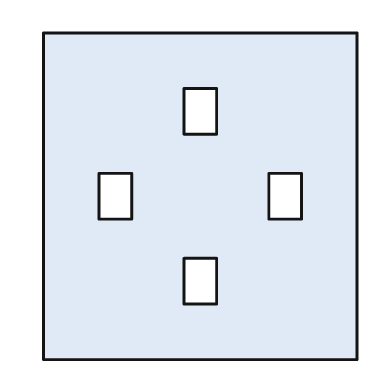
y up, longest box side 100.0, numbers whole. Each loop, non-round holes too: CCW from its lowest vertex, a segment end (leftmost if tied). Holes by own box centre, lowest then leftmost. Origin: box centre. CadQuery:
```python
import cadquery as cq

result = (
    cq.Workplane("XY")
    .moveTo(-48.0, -50.0)
    .lineTo(48.0, -50.0)
    .lineTo(48.0, 50.0)
    .lineTo(-48.0, 50.0)
    .close()
    .moveTo(-5.0, -33.0)
    .lineTo(5.0, -33.0)
    .lineTo(5.0, -19.0)
    .lineTo(-5.0, -19.0)
    .close()
    .moveTo(-31.0, -7.0)
    .lineTo(-21.0, -7.0)
    .lineTo(-21.0, 7.0)
    .lineTo(-31.0, 7.0)
    .close()
    .moveTo(21.0, -7.0)
    .lineTo(31.0, -7.0)
    .lineTo(31.0, 7.0)
    .lineTo(21.0, 7.0)
    .close()
    .moveTo(-5.0, 19.0)
    .lineTo(5.0, 19.0)
    .lineTo(5.0, 33.0)
    .lineTo(-5.0, 33.0)
    .close()
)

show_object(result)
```